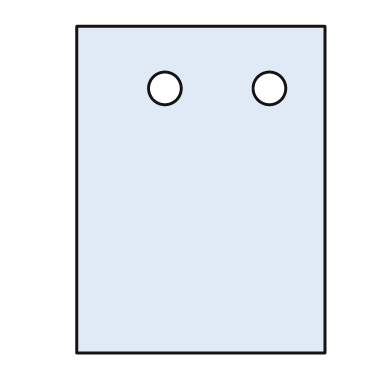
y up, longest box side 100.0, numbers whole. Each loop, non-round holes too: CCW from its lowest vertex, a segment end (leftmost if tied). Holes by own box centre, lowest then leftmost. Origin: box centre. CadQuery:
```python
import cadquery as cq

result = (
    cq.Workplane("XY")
    .moveTo(-38.0, -50.0)
    .lineTo(38.0, -50.0)
    .lineTo(38.0, 50.0)
    .lineTo(-38.0, 50.0)
    .close()
    .moveTo(-11.0, 31.0)
    .circle(5.0)
    .moveTo(21.0, 31.0)
    .circle(5.0)
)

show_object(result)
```